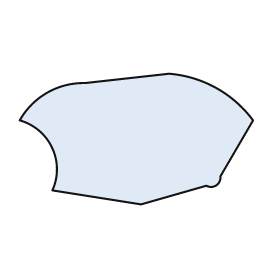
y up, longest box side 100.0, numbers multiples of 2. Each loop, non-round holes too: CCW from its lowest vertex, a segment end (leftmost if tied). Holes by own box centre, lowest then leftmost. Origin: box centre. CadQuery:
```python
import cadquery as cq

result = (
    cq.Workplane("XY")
    .moveTo(2.0, -28.0)
    .lineTo(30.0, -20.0)
    .threePointArc((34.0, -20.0), (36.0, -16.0))
    .lineTo(50.0, 8.0)
    .threePointArc((34.0, 22.0), (14.0, 28.0))
    .lineTo(-22.0, 24.0)
    .threePointArc((-38.0, 20.0), (-50.0, 8.0))
    .threePointArc((-36.0, -4.0), (-36.0, -22.0))
    .close()
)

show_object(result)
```